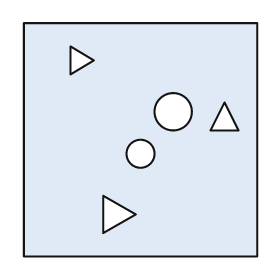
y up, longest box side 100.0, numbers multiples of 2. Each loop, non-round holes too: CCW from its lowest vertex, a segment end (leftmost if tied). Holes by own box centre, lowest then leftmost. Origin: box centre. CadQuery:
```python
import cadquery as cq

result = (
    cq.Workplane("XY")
    .moveTo(-50.0, -50.0)
    .lineTo(50.0, -50.0)
    .lineTo(50.0, 50.0)
    .lineTo(-50.0, 50.0)
    .close()
    .moveTo(-16.0, -40.0)
    .lineTo(-2.0, -32.0)
    .lineTo(-16.0, -24.0)
    .close()
    .moveTo(0.0, -6.0)
    .circle(6.0)
    .moveTo(30.0, 4.0)
    .lineTo(42.0, 4.0)
    .lineTo(36.0, 16.0)
    .close()
    .moveTo(14.0, 12.0)
    .circle(8.0)
    .moveTo(-30.0, 28.0)
    .lineTo(-20.0, 34.0)
    .lineTo(-30.0, 40.0)
    .close()
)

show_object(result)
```